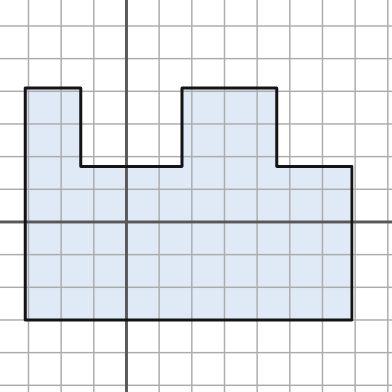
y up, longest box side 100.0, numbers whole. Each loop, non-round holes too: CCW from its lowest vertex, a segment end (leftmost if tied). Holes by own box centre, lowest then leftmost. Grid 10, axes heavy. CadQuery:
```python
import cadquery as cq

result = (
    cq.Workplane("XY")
    .moveTo(-31.0, -30.0)
    .lineTo(69.0, -30.0)
    .lineTo(69.0, 17.0)
    .lineTo(46.0, 17.0)
    .lineTo(46.0, 41.0)
    .lineTo(17.0, 41.0)
    .lineTo(17.0, 17.0)
    .lineTo(-14.0, 17.0)
    .lineTo(-14.0, 41.0)
    .lineTo(-31.0, 41.0)
    .close()
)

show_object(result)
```